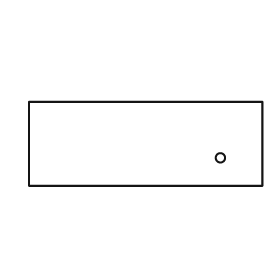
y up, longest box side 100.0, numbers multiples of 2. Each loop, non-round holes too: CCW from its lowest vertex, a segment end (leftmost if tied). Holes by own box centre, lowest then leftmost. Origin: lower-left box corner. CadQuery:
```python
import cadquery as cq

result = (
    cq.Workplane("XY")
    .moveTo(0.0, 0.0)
    .lineTo(100.0, 0.0)
    .lineTo(100.0, 36.0)
    .lineTo(0.0, 36.0)
    .close()
    .moveTo(82.0, 12.0)
    .circle(2.0)
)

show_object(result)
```